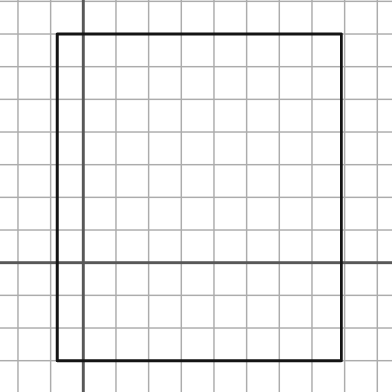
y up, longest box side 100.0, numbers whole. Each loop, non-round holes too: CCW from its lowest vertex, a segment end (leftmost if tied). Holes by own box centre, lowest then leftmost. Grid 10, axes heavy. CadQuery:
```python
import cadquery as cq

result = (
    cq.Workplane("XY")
    .moveTo(-8.0, -30.0)
    .lineTo(79.0, -30.0)
    .lineTo(79.0, 70.0)
    .lineTo(-8.0, 70.0)
    .close()
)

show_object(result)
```